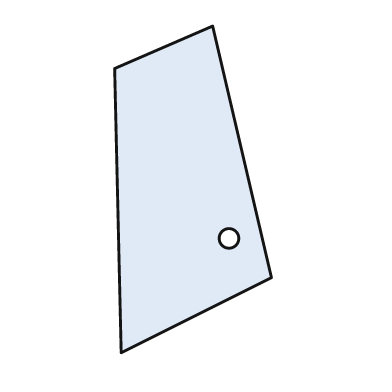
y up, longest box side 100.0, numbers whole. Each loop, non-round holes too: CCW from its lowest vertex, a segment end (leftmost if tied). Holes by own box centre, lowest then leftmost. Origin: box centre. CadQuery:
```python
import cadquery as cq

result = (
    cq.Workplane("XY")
    .moveTo(-22.0, -50.0)
    .lineTo(24.0, -27.0)
    .lineTo(6.0, 50.0)
    .lineTo(-24.0, 37.0)
    .close()
    .moveTo(11.0, -15.0)
    .circle(3.0)
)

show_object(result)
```